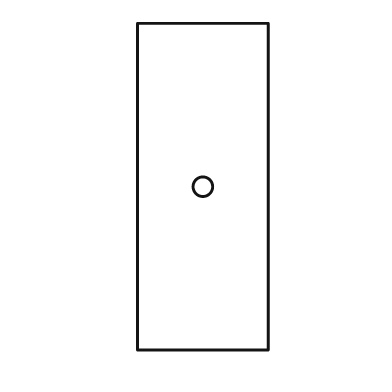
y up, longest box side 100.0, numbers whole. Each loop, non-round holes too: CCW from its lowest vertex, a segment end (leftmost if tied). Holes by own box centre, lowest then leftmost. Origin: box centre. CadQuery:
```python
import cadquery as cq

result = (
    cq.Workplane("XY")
    .moveTo(-20.0, -50.0)
    .lineTo(20.0, -50.0)
    .lineTo(20.0, 50.0)
    .lineTo(-20.0, 50.0)
    .close()
    .moveTo(0.0, 0.0)
    .circle(3.0)
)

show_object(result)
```